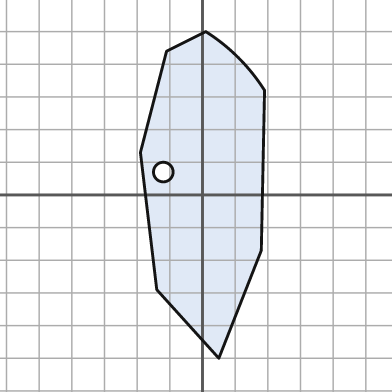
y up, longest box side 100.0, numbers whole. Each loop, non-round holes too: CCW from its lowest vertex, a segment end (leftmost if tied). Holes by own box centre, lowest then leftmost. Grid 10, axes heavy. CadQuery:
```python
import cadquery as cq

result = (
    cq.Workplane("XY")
    .moveTo(5.0, -50.0)
    .lineTo(18.0, -17.0)
    .lineTo(19.0, 32.0)
    .threePointArc((11.0, 42.0), (1.0, 50.0))
    .lineTo(-11.0, 44.0)
    .lineTo(-19.0, 13.0)
    .lineTo(-14.0, -29.0)
    .close()
    .moveTo(-12.0, 7.0)
    .circle(3.0)
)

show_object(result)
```